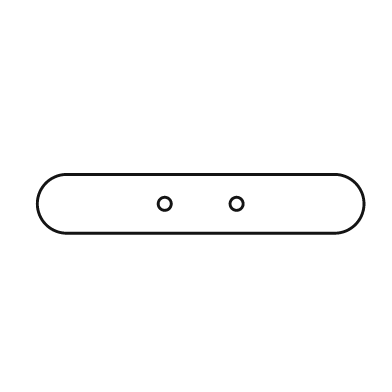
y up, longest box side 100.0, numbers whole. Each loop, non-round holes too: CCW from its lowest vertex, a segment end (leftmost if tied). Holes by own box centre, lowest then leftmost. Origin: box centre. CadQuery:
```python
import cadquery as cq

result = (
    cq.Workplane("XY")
    .moveTo(-41.0, -9.0)
    .lineTo(41.0, -9.0)
    .threePointArc((50.0, 0.0), (41.0, 9.0))
    .lineTo(-41.0, 9.0)
    .threePointArc((-50.0, 0.0), (-41.0, -9.0))
    .close()
    .moveTo(-11.0, 0.0)
    .circle(2.0)
    .moveTo(11.0, 0.0)
    .circle(2.0)
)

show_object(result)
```